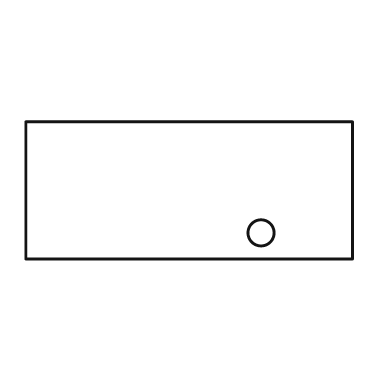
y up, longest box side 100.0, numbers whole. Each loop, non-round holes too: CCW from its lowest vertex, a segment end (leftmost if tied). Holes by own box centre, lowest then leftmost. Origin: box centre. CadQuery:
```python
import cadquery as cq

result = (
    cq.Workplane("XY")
    .moveTo(-50.0, -21.0)
    .lineTo(50.0, -21.0)
    .lineTo(50.0, 21.0)
    .lineTo(-50.0, 21.0)
    .close()
    .moveTo(22.0, -13.0)
    .circle(4.0)
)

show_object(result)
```